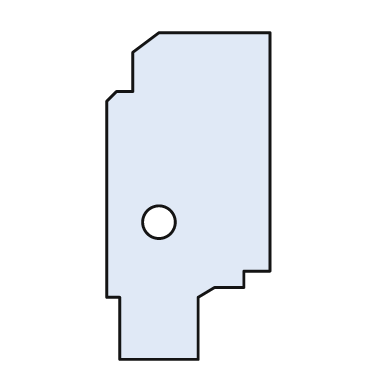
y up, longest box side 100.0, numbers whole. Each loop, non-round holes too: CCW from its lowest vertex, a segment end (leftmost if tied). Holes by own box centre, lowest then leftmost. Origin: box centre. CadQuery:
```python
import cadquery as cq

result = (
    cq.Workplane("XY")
    .moveTo(-21.0, -50.0)
    .lineTo(3.0, -50.0)
    .lineTo(3.0, -31.0)
    .lineTo(8.0, -28.0)
    .lineTo(17.0, -28.0)
    .lineTo(17.0, -23.0)
    .lineTo(25.0, -23.0)
    .lineTo(25.0, 50.0)
    .lineTo(-9.0, 50.0)
    .lineTo(-17.0, 44.0)
    .lineTo(-17.0, 32.0)
    .lineTo(-22.0, 32.0)
    .lineTo(-25.0, 29.0)
    .lineTo(-25.0, -31.0)
    .lineTo(-21.0, -31.0)
    .close()
    .moveTo(-9.0, -8.0)
    .circle(5.0)
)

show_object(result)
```